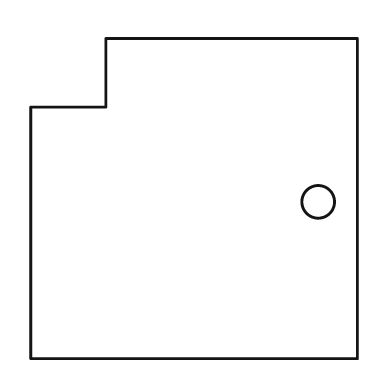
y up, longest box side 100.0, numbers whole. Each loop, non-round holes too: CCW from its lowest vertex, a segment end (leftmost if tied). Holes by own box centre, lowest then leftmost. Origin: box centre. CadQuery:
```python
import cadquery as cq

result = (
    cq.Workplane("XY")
    .moveTo(-50.0, -49.0)
    .lineTo(50.0, -49.0)
    .lineTo(50.0, 49.0)
    .lineTo(-27.0, 49.0)
    .lineTo(-27.0, 28.0)
    .lineTo(-50.0, 28.0)
    .close()
    .moveTo(38.0, -1.0)
    .circle(5.0)
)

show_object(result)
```